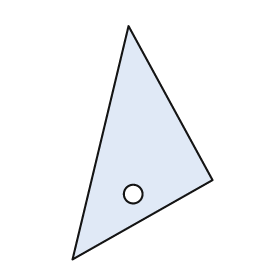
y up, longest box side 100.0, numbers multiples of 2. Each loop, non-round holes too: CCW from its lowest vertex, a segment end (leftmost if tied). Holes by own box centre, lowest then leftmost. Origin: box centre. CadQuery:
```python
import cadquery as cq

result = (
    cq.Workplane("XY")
    .moveTo(-30.0, -50.0)
    .lineTo(30.0, -16.0)
    .lineTo(-6.0, 50.0)
    .close()
    .moveTo(-4.0, -22.0)
    .circle(4.0)
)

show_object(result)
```